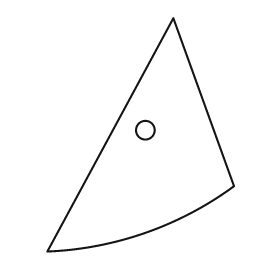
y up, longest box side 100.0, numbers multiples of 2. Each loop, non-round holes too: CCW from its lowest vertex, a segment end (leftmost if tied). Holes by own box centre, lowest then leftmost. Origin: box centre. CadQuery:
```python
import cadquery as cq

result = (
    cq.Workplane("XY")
    .moveTo(-40.0, -50.0)
    .threePointArc((2.0, -42.0), (40.0, -22.0))
    .lineTo(14.0, 50.0)
    .close()
    .moveTo(2.0, 2.0)
    .circle(4.0)
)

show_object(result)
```